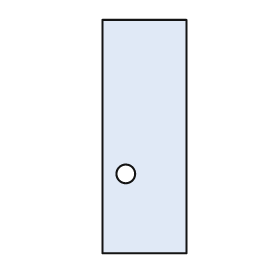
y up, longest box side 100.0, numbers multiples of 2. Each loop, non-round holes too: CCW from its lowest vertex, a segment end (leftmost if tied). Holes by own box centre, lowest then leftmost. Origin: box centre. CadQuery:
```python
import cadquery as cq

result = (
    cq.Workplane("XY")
    .moveTo(-18.0, -50.0)
    .lineTo(18.0, -50.0)
    .lineTo(18.0, 50.0)
    .lineTo(-18.0, 50.0)
    .close()
    .moveTo(-8.0, -16.0)
    .circle(4.0)
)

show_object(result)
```